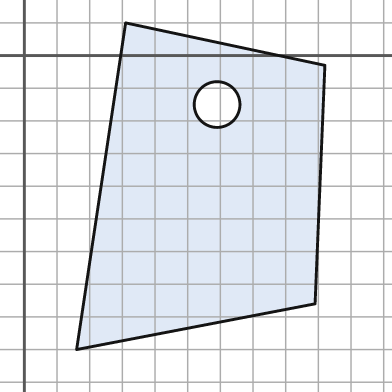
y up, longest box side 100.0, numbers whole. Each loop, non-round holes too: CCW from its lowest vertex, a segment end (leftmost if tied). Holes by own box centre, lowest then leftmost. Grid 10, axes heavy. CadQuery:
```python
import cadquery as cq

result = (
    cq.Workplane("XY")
    .moveTo(16.0, -90.0)
    .lineTo(89.0, -76.0)
    .lineTo(92.0, -3.0)
    .lineTo(31.0, 10.0)
    .close()
    .moveTo(59.0, -15.0)
    .circle(7.0)
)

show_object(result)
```